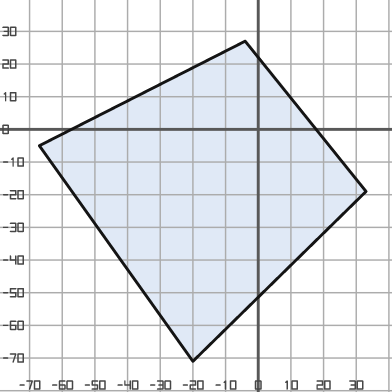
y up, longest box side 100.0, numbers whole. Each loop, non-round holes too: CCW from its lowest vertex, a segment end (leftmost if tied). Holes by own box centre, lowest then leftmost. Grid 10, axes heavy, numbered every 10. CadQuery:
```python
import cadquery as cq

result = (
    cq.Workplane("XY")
    .moveTo(-20.0, -71.0)
    .lineTo(33.0, -19.0)
    .lineTo(-4.0, 27.0)
    .lineTo(-67.0, -5.0)
    .close()
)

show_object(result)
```